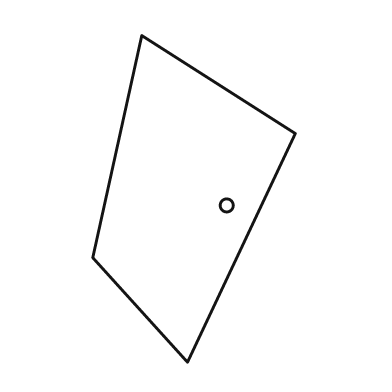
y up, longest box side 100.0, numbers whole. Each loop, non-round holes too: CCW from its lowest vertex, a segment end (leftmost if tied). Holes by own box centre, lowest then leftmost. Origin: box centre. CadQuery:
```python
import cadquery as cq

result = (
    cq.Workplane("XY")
    .moveTo(-2.0, -50.0)
    .lineTo(31.0, 20.0)
    .lineTo(-16.0, 50.0)
    .lineTo(-31.0, -18.0)
    .close()
    .moveTo(10.0, -2.0)
    .circle(2.0)
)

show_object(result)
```